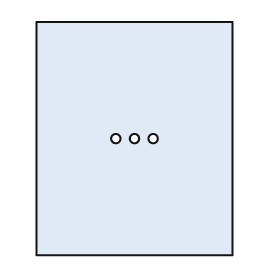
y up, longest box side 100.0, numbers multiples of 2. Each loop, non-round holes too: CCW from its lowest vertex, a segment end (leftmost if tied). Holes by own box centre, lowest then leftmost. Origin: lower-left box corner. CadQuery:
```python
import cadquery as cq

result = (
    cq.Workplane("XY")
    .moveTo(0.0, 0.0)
    .lineTo(84.0, 0.0)
    .lineTo(84.0, 100.0)
    .lineTo(0.0, 100.0)
    .close()
    .moveTo(34.0, 50.0)
    .circle(2.0)
    .moveTo(42.0, 50.0)
    .circle(2.0)
    .moveTo(50.0, 50.0)
    .circle(2.0)
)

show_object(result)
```